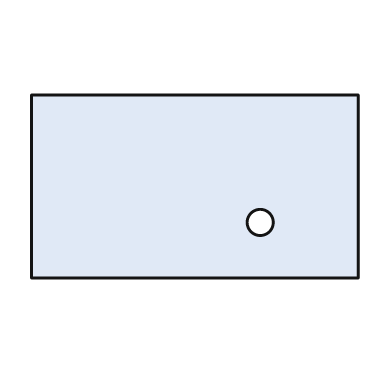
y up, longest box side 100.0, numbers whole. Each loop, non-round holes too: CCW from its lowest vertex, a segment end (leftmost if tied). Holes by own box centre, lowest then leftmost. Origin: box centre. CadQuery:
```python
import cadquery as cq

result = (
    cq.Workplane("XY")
    .moveTo(-50.0, -28.0)
    .lineTo(50.0, -28.0)
    .lineTo(50.0, 28.0)
    .lineTo(-50.0, 28.0)
    .close()
    .moveTo(20.0, -11.0)
    .circle(4.0)
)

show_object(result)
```